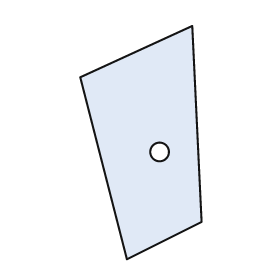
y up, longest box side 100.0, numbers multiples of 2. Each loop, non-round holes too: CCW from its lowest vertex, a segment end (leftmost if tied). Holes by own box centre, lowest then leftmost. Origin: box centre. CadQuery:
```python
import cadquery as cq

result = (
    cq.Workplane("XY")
    .moveTo(-6.0, -50.0)
    .lineTo(26.0, -34.0)
    .lineTo(22.0, 50.0)
    .lineTo(-26.0, 28.0)
    .close()
    .moveTo(8.0, -4.0)
    .circle(4.0)
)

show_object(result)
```